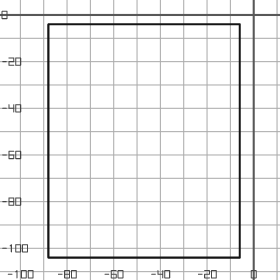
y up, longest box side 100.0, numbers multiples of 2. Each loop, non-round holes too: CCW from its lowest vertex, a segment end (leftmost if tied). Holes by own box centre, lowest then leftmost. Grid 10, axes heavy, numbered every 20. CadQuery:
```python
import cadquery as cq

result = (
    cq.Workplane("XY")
    .moveTo(-88.0, -104.0)
    .lineTo(-6.0, -104.0)
    .lineTo(-6.0, -4.0)
    .lineTo(-88.0, -4.0)
    .close()
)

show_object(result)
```